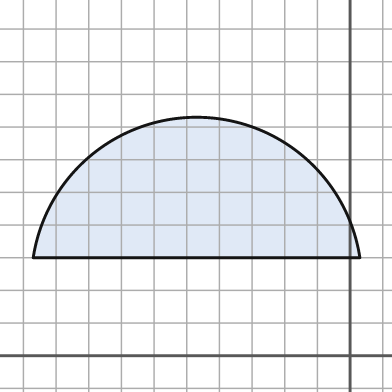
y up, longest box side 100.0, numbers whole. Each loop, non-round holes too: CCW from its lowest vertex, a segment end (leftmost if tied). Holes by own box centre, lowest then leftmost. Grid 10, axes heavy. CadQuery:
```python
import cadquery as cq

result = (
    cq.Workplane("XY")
    .moveTo(-97.0, 30.0)
    .lineTo(3.0, 30.0)
    .threePointArc((-47.0, 73.0), (-97.0, 30.0))
    .close()
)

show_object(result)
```